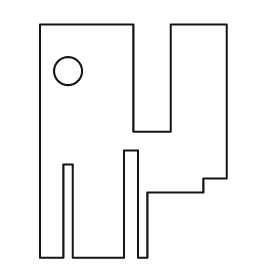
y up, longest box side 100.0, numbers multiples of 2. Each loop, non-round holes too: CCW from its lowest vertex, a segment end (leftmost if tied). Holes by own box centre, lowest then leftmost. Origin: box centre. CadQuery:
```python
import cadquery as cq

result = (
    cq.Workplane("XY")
    .moveTo(-40.0, -50.0)
    .lineTo(-30.0, -50.0)
    .lineTo(-30.0, -10.0)
    .lineTo(-26.0, -10.0)
    .lineTo(-26.0, -50.0)
    .lineTo(-4.0, -50.0)
    .lineTo(-4.0, -4.0)
    .lineTo(2.0, -4.0)
    .lineTo(2.0, -50.0)
    .lineTo(6.0, -50.0)
    .lineTo(6.0, -22.0)
    .lineTo(30.0, -22.0)
    .lineTo(30.0, -16.0)
    .lineTo(40.0, -16.0)
    .lineTo(40.0, 50.0)
    .lineTo(16.0, 50.0)
    .lineTo(16.0, 4.0)
    .lineTo(0.0, 4.0)
    .lineTo(0.0, 50.0)
    .lineTo(-40.0, 50.0)
    .close()
    .moveTo(-28.0, 30.0)
    .circle(6.0)
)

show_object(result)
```